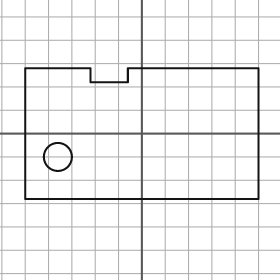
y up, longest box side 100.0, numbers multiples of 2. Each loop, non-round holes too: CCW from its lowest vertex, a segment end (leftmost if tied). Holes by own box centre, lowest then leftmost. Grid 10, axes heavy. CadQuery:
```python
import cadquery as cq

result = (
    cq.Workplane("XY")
    .moveTo(-50.0, -28.0)
    .lineTo(50.0, -28.0)
    .lineTo(50.0, 28.0)
    .lineTo(-6.0, 28.0)
    .lineTo(-6.0, 22.0)
    .lineTo(-22.0, 22.0)
    .lineTo(-22.0, 28.0)
    .lineTo(-50.0, 28.0)
    .close()
    .moveTo(-36.0, -10.0)
    .circle(6.0)
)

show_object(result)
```